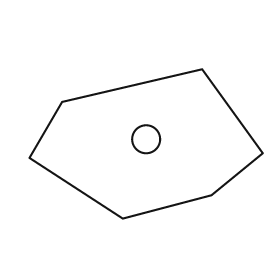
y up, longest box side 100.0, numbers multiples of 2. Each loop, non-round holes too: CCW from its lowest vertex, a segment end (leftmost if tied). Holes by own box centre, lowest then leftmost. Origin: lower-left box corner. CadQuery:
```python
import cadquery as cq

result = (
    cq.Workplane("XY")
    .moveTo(40.0, 0.0)
    .lineTo(78.0, 10.0)
    .lineTo(100.0, 28.0)
    .lineTo(74.0, 64.0)
    .lineTo(14.0, 50.0)
    .lineTo(0.0, 26.0)
    .close()
    .moveTo(50.0, 34.0)
    .circle(6.0)
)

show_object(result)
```